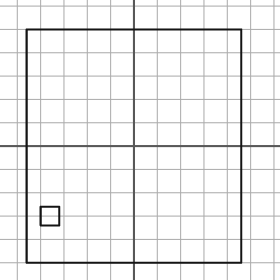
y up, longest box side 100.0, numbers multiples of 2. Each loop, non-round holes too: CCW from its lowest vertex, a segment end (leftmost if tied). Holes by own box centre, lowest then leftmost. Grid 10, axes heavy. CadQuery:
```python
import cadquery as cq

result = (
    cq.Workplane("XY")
    .moveTo(-46.0, -50.0)
    .lineTo(46.0, -50.0)
    .lineTo(46.0, 50.0)
    .lineTo(-46.0, 50.0)
    .close()
    .moveTo(-40.0, -34.0)
    .lineTo(-32.0, -34.0)
    .lineTo(-32.0, -26.0)
    .lineTo(-40.0, -26.0)
    .close()
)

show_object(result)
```